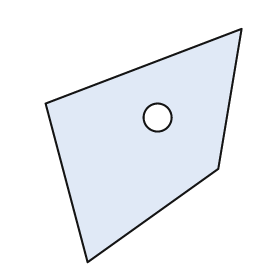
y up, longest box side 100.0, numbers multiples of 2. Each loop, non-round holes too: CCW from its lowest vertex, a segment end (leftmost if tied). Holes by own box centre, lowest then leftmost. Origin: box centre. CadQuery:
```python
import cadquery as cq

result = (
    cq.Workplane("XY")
    .moveTo(-24.0, -50.0)
    .lineTo(32.0, -10.0)
    .lineTo(42.0, 50.0)
    .lineTo(-42.0, 18.0)
    .close()
    .moveTo(6.0, 12.0)
    .circle(6.0)
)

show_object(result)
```